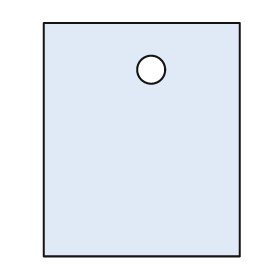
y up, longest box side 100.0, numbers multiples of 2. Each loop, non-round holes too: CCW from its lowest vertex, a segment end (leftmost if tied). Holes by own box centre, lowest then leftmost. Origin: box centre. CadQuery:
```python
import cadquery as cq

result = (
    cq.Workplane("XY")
    .moveTo(-42.0, -50.0)
    .lineTo(42.0, -50.0)
    .lineTo(42.0, 50.0)
    .lineTo(-42.0, 50.0)
    .close()
    .moveTo(4.0, 30.0)
    .circle(6.0)
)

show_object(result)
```